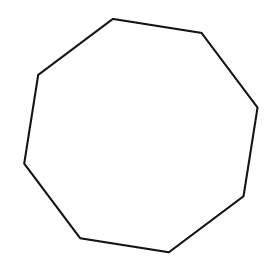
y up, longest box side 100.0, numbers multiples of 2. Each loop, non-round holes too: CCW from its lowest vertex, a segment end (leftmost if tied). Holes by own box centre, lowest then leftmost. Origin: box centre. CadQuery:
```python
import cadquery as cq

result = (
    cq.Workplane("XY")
    .moveTo(12.0, -50.0)
    .lineTo(44.0, -26.0)
    .lineTo(50.0, 12.0)
    .lineTo(26.0, 44.0)
    .lineTo(-12.0, 50.0)
    .lineTo(-44.0, 26.0)
    .lineTo(-50.0, -12.0)
    .lineTo(-26.0, -44.0)
    .close()
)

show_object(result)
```